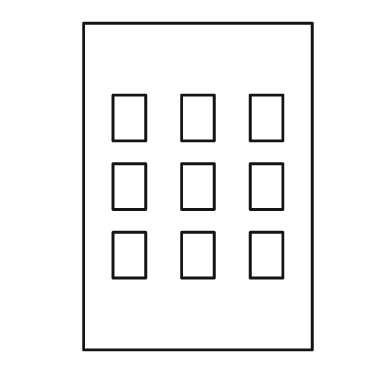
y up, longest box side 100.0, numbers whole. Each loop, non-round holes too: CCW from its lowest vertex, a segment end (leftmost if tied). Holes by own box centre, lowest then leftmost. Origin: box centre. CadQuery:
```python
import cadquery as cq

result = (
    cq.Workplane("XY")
    .moveTo(-35.0, -50.0)
    .lineTo(35.0, -50.0)
    .lineTo(35.0, 50.0)
    .lineTo(-35.0, 50.0)
    .close()
    .moveTo(-26.0, -28.0)
    .lineTo(-16.0, -28.0)
    .lineTo(-16.0, -14.0)
    .lineTo(-26.0, -14.0)
    .close()
    .moveTo(-5.0, -28.0)
    .lineTo(5.0, -28.0)
    .lineTo(5.0, -14.0)
    .lineTo(-5.0, -14.0)
    .close()
    .moveTo(16.0, -28.0)
    .lineTo(26.0, -28.0)
    .lineTo(26.0, -14.0)
    .lineTo(16.0, -14.0)
    .close()
    .moveTo(-26.0, -7.0)
    .lineTo(-16.0, -7.0)
    .lineTo(-16.0, 7.0)
    .lineTo(-26.0, 7.0)
    .close()
    .moveTo(-5.0, -7.0)
    .lineTo(5.0, -7.0)
    .lineTo(5.0, 7.0)
    .lineTo(-5.0, 7.0)
    .close()
    .moveTo(16.0, -7.0)
    .lineTo(26.0, -7.0)
    .lineTo(26.0, 7.0)
    .lineTo(16.0, 7.0)
    .close()
    .moveTo(-26.0, 14.0)
    .lineTo(-16.0, 14.0)
    .lineTo(-16.0, 28.0)
    .lineTo(-26.0, 28.0)
    .close()
    .moveTo(-5.0, 14.0)
    .lineTo(5.0, 14.0)
    .lineTo(5.0, 28.0)
    .lineTo(-5.0, 28.0)
    .close()
    .moveTo(16.0, 14.0)
    .lineTo(26.0, 14.0)
    .lineTo(26.0, 28.0)
    .lineTo(16.0, 28.0)
    .close()
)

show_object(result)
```